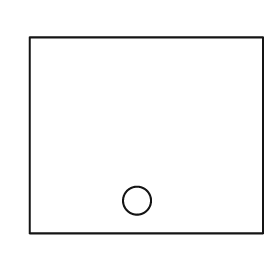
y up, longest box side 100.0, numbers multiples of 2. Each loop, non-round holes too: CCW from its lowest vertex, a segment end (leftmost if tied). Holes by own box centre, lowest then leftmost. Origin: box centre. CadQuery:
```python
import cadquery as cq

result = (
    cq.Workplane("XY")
    .moveTo(-50.0, -42.0)
    .lineTo(50.0, -42.0)
    .lineTo(50.0, 42.0)
    .lineTo(-50.0, 42.0)
    .close()
    .moveTo(-4.0, -28.0)
    .circle(6.0)
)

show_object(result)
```